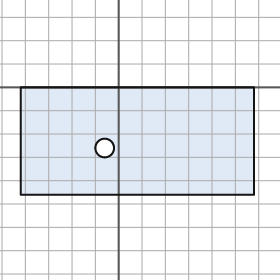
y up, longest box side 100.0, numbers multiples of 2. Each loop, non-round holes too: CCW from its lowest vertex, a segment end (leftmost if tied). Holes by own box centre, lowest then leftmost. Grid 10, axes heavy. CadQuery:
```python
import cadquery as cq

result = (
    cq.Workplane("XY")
    .moveTo(-42.0, -46.0)
    .lineTo(58.0, -46.0)
    .lineTo(58.0, 0.0)
    .lineTo(-42.0, 0.0)
    .close()
    .moveTo(-6.0, -26.0)
    .circle(4.0)
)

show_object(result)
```